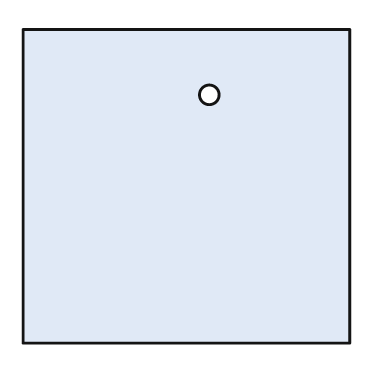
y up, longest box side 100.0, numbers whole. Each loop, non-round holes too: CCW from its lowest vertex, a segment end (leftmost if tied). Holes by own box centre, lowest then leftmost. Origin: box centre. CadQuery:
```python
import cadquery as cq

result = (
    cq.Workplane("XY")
    .moveTo(-50.0, -48.0)
    .lineTo(50.0, -48.0)
    .lineTo(50.0, 48.0)
    .lineTo(-50.0, 48.0)
    .close()
    .moveTo(7.0, 28.0)
    .circle(3.0)
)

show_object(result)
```